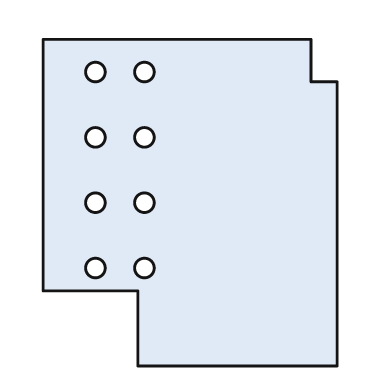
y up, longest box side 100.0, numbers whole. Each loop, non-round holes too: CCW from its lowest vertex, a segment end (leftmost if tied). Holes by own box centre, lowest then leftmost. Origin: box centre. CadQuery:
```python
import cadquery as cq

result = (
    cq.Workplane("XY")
    .moveTo(-16.0, -50.0)
    .lineTo(45.0, -50.0)
    .lineTo(45.0, 37.0)
    .lineTo(37.0, 37.0)
    .lineTo(37.0, 50.0)
    .lineTo(-45.0, 50.0)
    .lineTo(-45.0, -27.0)
    .lineTo(-16.0, -27.0)
    .close()
    .moveTo(-29.0, -20.0)
    .circle(3.0)
    .moveTo(-14.0, -20.0)
    .circle(3.0)
    .moveTo(-29.0, 0.0)
    .circle(3.0)
    .moveTo(-14.0, 0.0)
    .circle(3.0)
    .moveTo(-29.0, 20.0)
    .circle(3.0)
    .moveTo(-14.0, 20.0)
    .circle(3.0)
    .moveTo(-29.0, 40.0)
    .circle(3.0)
    .moveTo(-14.0, 40.0)
    .circle(3.0)
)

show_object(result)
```